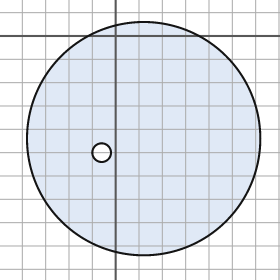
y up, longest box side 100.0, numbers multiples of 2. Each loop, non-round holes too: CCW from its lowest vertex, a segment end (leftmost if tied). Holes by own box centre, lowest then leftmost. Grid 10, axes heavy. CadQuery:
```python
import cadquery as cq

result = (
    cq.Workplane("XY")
    .moveTo(12.0, -44.0)
    .circle(50.0)
    .moveTo(-6.0, -50.0)
    .circle(4.0)
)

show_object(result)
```